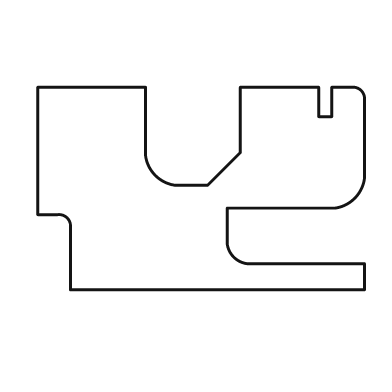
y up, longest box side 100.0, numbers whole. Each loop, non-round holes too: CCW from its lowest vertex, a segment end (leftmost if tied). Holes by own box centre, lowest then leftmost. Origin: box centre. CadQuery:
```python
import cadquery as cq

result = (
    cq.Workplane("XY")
    .moveTo(-40.0, -31.0)
    .lineTo(50.0, -31.0)
    .lineTo(50.0, -23.0)
    .lineTo(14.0, -23.0)
    .threePointArc((10.0, -21.0), (8.0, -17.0))
    .lineTo(8.0, -6.0)
    .lineTo(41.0, -6.0)
    .threePointArc((47.0, -3.0), (50.0, 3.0))
    .lineTo(50.0, 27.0)
    .threePointArc((49.0, 30.0), (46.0, 31.0))
    .lineTo(40.0, 31.0)
    .lineTo(40.0, 22.0)
    .lineTo(36.0, 22.0)
    .lineTo(36.0, 31.0)
    .lineTo(12.0, 31.0)
    .lineTo(12.0, 11.0)
    .lineTo(2.0, 1.0)
    .lineTo(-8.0, 1.0)
    .threePointArc((-14.0, 4.0), (-17.0, 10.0))
    .lineTo(-17.0, 31.0)
    .lineTo(-50.0, 31.0)
    .lineTo(-50.0, -8.0)
    .lineTo(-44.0, -8.0)
    .threePointArc((-41.0, -9.0), (-40.0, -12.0))
    .close()
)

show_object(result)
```